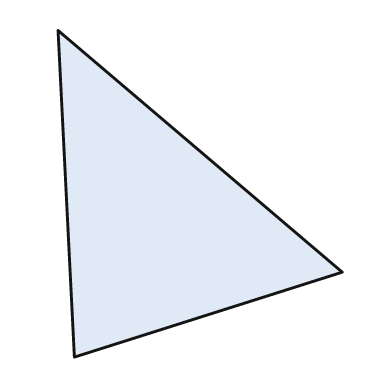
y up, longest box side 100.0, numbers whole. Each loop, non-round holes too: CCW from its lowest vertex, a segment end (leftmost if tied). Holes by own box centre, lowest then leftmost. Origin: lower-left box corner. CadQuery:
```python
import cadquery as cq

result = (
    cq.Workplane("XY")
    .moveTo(5.0, 0.0)
    .lineTo(87.0, 26.0)
    .lineTo(0.0, 100.0)
    .close()
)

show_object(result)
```